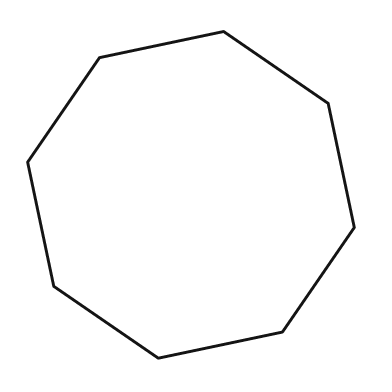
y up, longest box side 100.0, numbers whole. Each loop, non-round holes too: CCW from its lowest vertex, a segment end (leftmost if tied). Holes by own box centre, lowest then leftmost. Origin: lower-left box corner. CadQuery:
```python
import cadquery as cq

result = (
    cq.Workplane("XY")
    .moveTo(40.0, 0.0)
    .lineTo(78.0, 8.0)
    .lineTo(100.0, 40.0)
    .lineTo(92.0, 78.0)
    .lineTo(60.0, 100.0)
    .lineTo(22.0, 92.0)
    .lineTo(0.0, 60.0)
    .lineTo(8.0, 22.0)
    .close()
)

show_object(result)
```